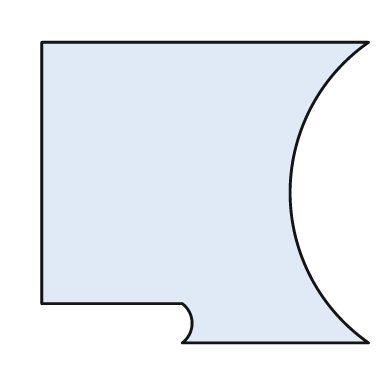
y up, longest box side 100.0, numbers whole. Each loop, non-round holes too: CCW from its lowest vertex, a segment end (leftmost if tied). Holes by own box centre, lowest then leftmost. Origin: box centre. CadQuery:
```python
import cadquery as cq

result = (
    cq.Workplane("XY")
    .moveTo(-7.0, -46.0)
    .lineTo(50.0, -46.0)
    .threePointArc((26.0, 0.0), (50.0, 46.0))
    .lineTo(-50.0, 46.0)
    .lineTo(-50.0, -34.0)
    .lineTo(-7.0, -34.0)
    .threePointArc((-4.0, -40.0), (-7.0, -46.0))
    .close()
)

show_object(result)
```